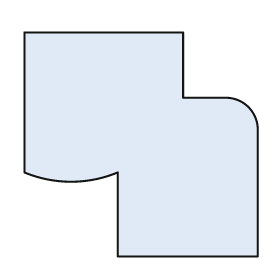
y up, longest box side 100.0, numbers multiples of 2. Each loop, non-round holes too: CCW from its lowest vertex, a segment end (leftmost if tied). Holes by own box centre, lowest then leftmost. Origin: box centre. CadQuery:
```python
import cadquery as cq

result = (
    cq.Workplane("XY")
    .moveTo(-10.0, -48.0)
    .lineTo(50.0, -48.0)
    .lineTo(50.0, 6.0)
    .threePointArc((46.0, 16.0), (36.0, 20.0))
    .lineTo(18.0, 20.0)
    .lineTo(18.0, 48.0)
    .lineTo(-50.0, 48.0)
    .lineTo(-50.0, -12.0)
    .threePointArc((-30.0, -16.0), (-10.0, -12.0))
    .close()
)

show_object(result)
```